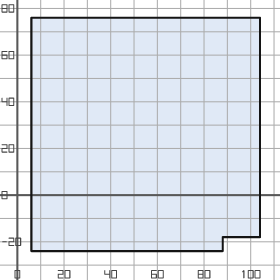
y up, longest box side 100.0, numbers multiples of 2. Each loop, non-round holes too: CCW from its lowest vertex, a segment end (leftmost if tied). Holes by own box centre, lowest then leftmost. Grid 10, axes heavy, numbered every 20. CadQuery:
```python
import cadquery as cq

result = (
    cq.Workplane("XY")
    .moveTo(6.0, -24.0)
    .lineTo(88.0, -24.0)
    .lineTo(88.0, -18.0)
    .lineTo(104.0, -18.0)
    .lineTo(104.0, 76.0)
    .lineTo(6.0, 76.0)
    .close()
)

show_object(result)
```